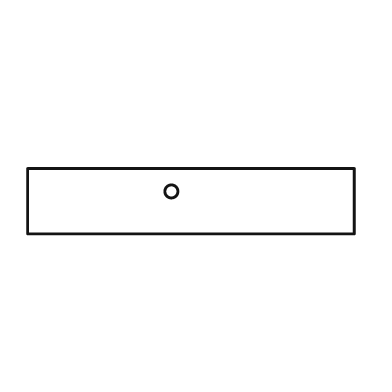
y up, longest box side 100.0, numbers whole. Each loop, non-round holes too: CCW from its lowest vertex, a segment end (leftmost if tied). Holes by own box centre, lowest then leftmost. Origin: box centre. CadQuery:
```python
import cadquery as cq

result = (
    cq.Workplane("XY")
    .moveTo(-50.0, -10.0)
    .lineTo(50.0, -10.0)
    .lineTo(50.0, 10.0)
    .lineTo(-50.0, 10.0)
    .close()
    .moveTo(-6.0, 3.0)
    .circle(2.0)
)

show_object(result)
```